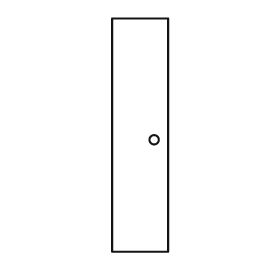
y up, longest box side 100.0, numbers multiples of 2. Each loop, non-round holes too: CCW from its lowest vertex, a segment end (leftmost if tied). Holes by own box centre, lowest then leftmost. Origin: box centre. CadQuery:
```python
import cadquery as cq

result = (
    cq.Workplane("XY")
    .moveTo(-12.0, -50.0)
    .lineTo(12.0, -50.0)
    .lineTo(12.0, 50.0)
    .lineTo(-12.0, 50.0)
    .close()
    .moveTo(6.0, -2.0)
    .circle(2.0)
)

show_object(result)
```